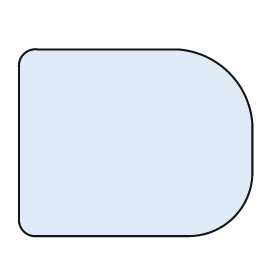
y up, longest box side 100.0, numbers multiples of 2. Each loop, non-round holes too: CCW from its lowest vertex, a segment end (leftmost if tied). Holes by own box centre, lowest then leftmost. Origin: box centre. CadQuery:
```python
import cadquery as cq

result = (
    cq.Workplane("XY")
    .moveTo(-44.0, -40.0)
    .lineTo(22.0, -40.0)
    .threePointArc((42.0, -32.0), (50.0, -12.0))
    .lineTo(50.0, 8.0)
    .threePointArc((40.0, 30.0), (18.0, 40.0))
    .lineTo(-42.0, 40.0)
    .threePointArc((-48.0, 38.0), (-50.0, 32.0))
    .lineTo(-50.0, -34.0)
    .threePointArc((-48.0, -38.0), (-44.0, -40.0))
    .close()
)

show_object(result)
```